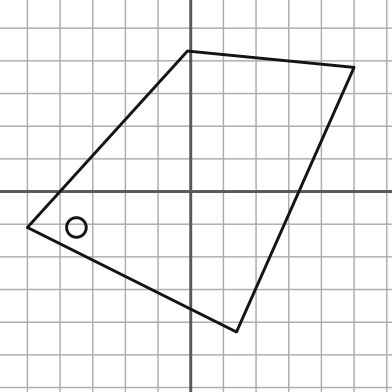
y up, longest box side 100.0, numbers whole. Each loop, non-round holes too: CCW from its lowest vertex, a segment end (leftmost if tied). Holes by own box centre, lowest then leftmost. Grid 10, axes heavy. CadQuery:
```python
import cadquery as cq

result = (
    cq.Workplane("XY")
    .moveTo(14.0, -43.0)
    .lineTo(50.0, 38.0)
    .lineTo(-1.0, 43.0)
    .lineTo(-50.0, -11.0)
    .close()
    .moveTo(-35.0, -11.0)
    .circle(3.0)
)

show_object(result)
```